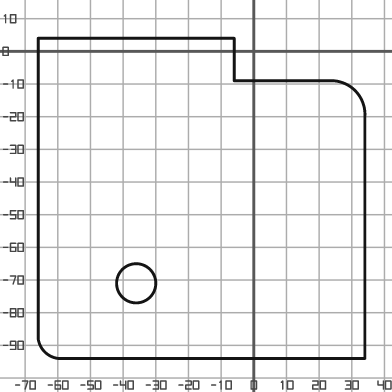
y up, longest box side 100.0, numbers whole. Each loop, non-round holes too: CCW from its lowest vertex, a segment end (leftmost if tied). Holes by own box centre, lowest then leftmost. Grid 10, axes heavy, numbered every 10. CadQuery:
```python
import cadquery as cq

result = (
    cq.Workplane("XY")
    .moveTo(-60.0, -94.0)
    .lineTo(34.0, -94.0)
    .lineTo(34.0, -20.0)
    .threePointArc((31.0, -12.0), (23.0, -9.0))
    .lineTo(-6.0, -9.0)
    .lineTo(-6.0, 4.0)
    .lineTo(-66.0, 4.0)
    .lineTo(-66.0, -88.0)
    .threePointArc((-64.0, -92.0), (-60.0, -94.0))
    .close()
    .moveTo(-36.0, -71.0)
    .circle(6.0)
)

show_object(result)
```